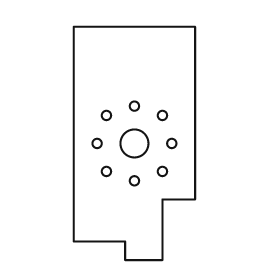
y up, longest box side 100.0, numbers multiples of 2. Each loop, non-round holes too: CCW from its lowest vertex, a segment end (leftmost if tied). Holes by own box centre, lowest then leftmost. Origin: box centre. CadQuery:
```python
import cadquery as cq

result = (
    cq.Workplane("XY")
    .moveTo(-4.0, -50.0)
    .lineTo(12.0, -50.0)
    .lineTo(12.0, -24.0)
    .lineTo(26.0, -24.0)
    .lineTo(26.0, 50.0)
    .lineTo(-26.0, 50.0)
    .lineTo(-26.0, -42.0)
    .lineTo(-4.0, -42.0)
    .close()
    .moveTo(0.0, -16.0)
    .circle(2.0)
    .moveTo(-12.0, -12.0)
    .circle(2.0)
    .moveTo(12.0, -12.0)
    .circle(2.0)
    .moveTo(-16.0, 0.0)
    .circle(2.0)
    .moveTo(0.0, 0.0)
    .circle(6.0)
    .moveTo(16.0, 0.0)
    .circle(2.0)
    .moveTo(-12.0, 12.0)
    .circle(2.0)
    .moveTo(12.0, 12.0)
    .circle(2.0)
    .moveTo(0.0, 16.0)
    .circle(2.0)
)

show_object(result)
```